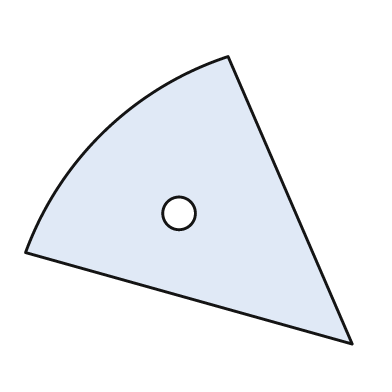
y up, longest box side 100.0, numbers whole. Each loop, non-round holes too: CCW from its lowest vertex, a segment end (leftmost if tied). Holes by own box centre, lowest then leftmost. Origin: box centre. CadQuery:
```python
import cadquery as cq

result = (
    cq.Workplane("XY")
    .moveTo(50.0, -44.0)
    .lineTo(12.0, 44.0)
    .threePointArc((-26.0, 21.0), (-50.0, -16.0))
    .close()
    .moveTo(-3.0, -4.0)
    .circle(5.0)
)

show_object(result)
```